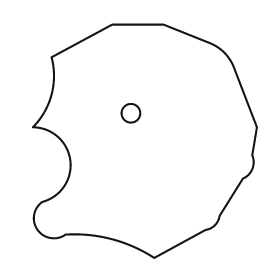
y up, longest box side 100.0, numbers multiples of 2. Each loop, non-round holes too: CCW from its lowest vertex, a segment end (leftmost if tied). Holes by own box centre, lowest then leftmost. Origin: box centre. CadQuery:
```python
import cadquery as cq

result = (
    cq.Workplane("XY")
    .moveTo(4.0, -50.0)
    .lineTo(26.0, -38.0)
    .threePointArc((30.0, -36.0), (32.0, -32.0))
    .lineTo(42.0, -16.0)
    .threePointArc((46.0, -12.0), (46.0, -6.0))
    .lineTo(48.0, 6.0)
    .lineTo(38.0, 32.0)
    .threePointArc((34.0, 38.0), (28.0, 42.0))
    .lineTo(8.0, 50.0)
    .lineTo(-14.0, 50.0)
    .lineTo(-40.0, 36.0)
    .threePointArc((-40.0, 20.0), (-48.0, 6.0))
    .threePointArc((-32.0, -8.0), (-44.0, -26.0))
    .threePointArc((-46.0, -38.0), (-34.0, -40.0))
    .threePointArc((-14.0, -42.0), (4.0, -50.0))
    .close()
    .moveTo(-6.0, 12.0)
    .circle(4.0)
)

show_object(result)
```